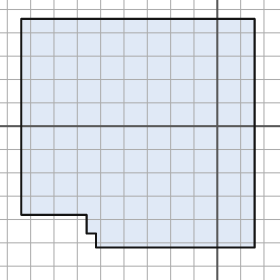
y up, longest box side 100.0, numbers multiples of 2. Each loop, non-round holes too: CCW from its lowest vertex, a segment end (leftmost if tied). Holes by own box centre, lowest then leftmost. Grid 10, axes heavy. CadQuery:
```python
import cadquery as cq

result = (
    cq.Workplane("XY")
    .moveTo(-52.0, -52.0)
    .lineTo(16.0, -52.0)
    .lineTo(16.0, 46.0)
    .lineTo(-84.0, 46.0)
    .lineTo(-84.0, -38.0)
    .lineTo(-56.0, -38.0)
    .lineTo(-56.0, -46.0)
    .lineTo(-52.0, -46.0)
    .close()
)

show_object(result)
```